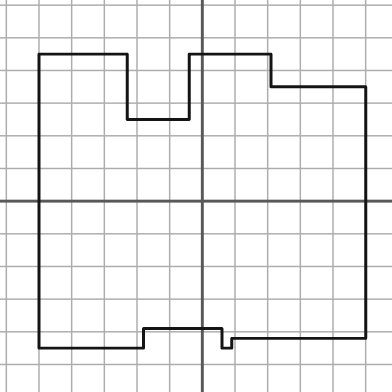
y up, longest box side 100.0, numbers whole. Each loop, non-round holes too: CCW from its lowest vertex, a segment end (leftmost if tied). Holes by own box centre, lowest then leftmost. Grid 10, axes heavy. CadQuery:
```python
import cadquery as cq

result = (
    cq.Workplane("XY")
    .moveTo(-50.0, -45.0)
    .lineTo(-18.0, -45.0)
    .lineTo(-18.0, -39.0)
    .lineTo(6.0, -39.0)
    .lineTo(6.0, -45.0)
    .lineTo(9.0, -45.0)
    .lineTo(9.0, -42.0)
    .lineTo(50.0, -42.0)
    .lineTo(50.0, 35.0)
    .lineTo(21.0, 35.0)
    .lineTo(21.0, 45.0)
    .lineTo(-4.0, 45.0)
    .lineTo(-4.0, 25.0)
    .lineTo(-23.0, 25.0)
    .lineTo(-23.0, 45.0)
    .lineTo(-50.0, 45.0)
    .close()
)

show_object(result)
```